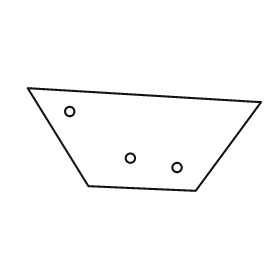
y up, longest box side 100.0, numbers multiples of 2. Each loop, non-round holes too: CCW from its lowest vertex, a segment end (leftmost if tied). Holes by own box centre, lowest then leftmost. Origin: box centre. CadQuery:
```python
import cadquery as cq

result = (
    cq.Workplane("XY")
    .moveTo(22.0, -22.0)
    .lineTo(50.0, 16.0)
    .lineTo(-50.0, 22.0)
    .lineTo(-24.0, -20.0)
    .close()
    .moveTo(14.0, -12.0)
    .circle(2.0)
    .moveTo(-6.0, -8.0)
    .circle(2.0)
    .moveTo(-32.0, 12.0)
    .circle(2.0)
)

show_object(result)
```